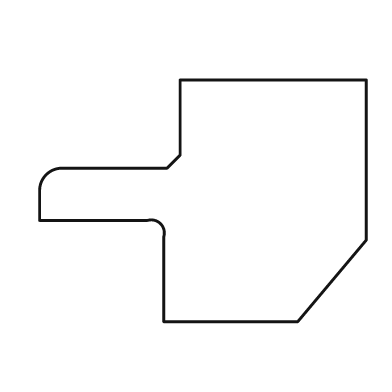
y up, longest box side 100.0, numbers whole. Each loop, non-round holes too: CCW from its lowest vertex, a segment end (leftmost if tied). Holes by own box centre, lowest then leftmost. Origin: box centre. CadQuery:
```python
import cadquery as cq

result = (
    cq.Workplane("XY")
    .moveTo(-12.0, -37.0)
    .lineTo(29.0, -37.0)
    .lineTo(50.0, -12.0)
    .lineTo(50.0, 37.0)
    .lineTo(-7.0, 37.0)
    .lineTo(-7.0, 14.0)
    .lineTo(-11.0, 10.0)
    .lineTo(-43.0, 10.0)
    .threePointArc((-48.0, 8.0), (-50.0, 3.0))
    .lineTo(-50.0, -6.0)
    .lineTo(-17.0, -6.0)
    .threePointArc((-13.0, -7.0), (-12.0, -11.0))
    .close()
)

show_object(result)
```